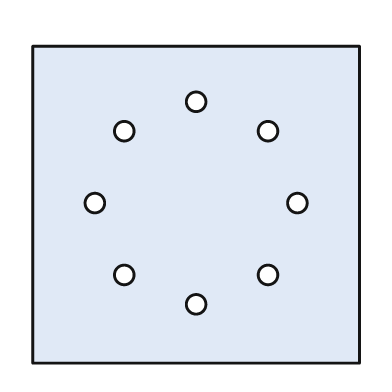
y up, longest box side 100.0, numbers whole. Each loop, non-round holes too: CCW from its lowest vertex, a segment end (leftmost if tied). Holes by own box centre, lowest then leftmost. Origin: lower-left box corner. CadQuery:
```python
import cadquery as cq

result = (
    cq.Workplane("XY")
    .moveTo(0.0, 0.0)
    .lineTo(100.0, 0.0)
    .lineTo(100.0, 97.0)
    .lineTo(0.0, 97.0)
    .close()
    .moveTo(50.0, 18.0)
    .circle(3.0)
    .moveTo(28.0, 27.0)
    .circle(3.0)
    .moveTo(72.0, 27.0)
    .circle(3.0)
    .moveTo(19.0, 49.0)
    .circle(3.0)
    .moveTo(81.0, 49.0)
    .circle(3.0)
    .moveTo(28.0, 71.0)
    .circle(3.0)
    .moveTo(72.0, 71.0)
    .circle(3.0)
    .moveTo(50.0, 80.0)
    .circle(3.0)
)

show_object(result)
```